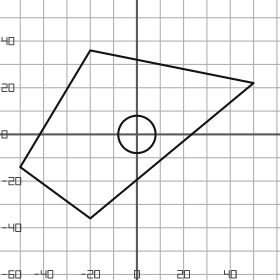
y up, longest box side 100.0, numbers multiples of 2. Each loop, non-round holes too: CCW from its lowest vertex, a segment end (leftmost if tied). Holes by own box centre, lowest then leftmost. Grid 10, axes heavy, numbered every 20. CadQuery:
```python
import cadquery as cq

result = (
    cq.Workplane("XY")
    .moveTo(-20.0, -36.0)
    .lineTo(50.0, 22.0)
    .lineTo(-20.0, 36.0)
    .lineTo(-50.0, -14.0)
    .close()
    .moveTo(0.0, 0.0)
    .circle(8.0)
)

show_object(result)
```